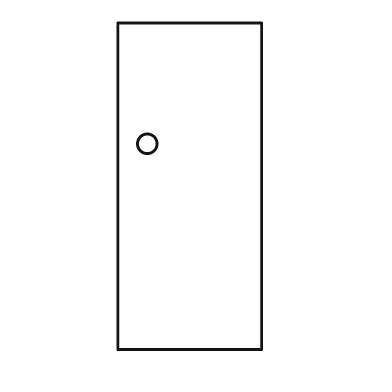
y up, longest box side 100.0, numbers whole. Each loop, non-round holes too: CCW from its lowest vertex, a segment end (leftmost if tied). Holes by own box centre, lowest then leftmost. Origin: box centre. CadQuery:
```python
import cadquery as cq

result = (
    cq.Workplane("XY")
    .moveTo(-22.0, -50.0)
    .lineTo(22.0, -50.0)
    .lineTo(22.0, 50.0)
    .lineTo(-22.0, 50.0)
    .close()
    .moveTo(-13.0, 13.0)
    .circle(3.0)
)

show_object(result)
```